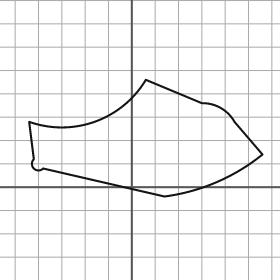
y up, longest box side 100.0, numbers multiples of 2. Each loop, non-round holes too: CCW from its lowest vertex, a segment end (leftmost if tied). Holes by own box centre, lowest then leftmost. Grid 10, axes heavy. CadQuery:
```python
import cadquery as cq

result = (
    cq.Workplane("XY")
    .moveTo(14.0, -4.0)
    .threePointArc((36.0, 2.0), (56.0, 14.0))
    .lineTo(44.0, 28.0)
    .threePointArc((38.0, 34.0), (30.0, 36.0))
    .lineTo(6.0, 46.0)
    .threePointArc((-16.0, 28.0), (-44.0, 28.0))
    .lineTo(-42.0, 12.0)
    .threePointArc((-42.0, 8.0), (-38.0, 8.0))
    .close()
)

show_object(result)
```